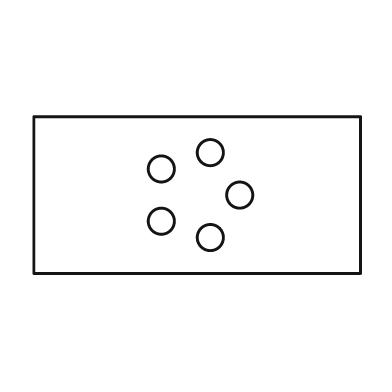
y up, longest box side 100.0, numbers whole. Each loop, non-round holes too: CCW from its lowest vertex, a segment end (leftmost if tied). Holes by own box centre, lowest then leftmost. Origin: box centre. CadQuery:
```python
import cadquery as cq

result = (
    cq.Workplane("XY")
    .moveTo(-50.0, -24.0)
    .lineTo(50.0, -24.0)
    .lineTo(50.0, 24.0)
    .lineTo(-50.0, 24.0)
    .close()
    .moveTo(4.0, -13.0)
    .circle(4.0)
    .moveTo(-11.0, -8.0)
    .circle(4.0)
    .moveTo(13.0, 0.0)
    .circle(4.0)
    .moveTo(-11.0, 8.0)
    .circle(4.0)
    .moveTo(4.0, 13.0)
    .circle(4.0)
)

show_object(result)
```